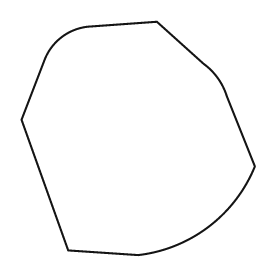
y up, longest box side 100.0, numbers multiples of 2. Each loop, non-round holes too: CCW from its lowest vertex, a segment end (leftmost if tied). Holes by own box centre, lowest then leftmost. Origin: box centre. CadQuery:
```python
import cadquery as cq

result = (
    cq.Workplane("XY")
    .moveTo(0.0, -50.0)
    .threePointArc((30.0, -38.0), (50.0, -12.0))
    .lineTo(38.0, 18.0)
    .threePointArc((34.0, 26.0), (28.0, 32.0))
    .lineTo(8.0, 50.0)
    .lineTo(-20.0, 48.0)
    .threePointArc((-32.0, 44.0), (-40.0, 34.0))
    .lineTo(-50.0, 8.0)
    .lineTo(-30.0, -48.0)
    .close()
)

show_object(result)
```